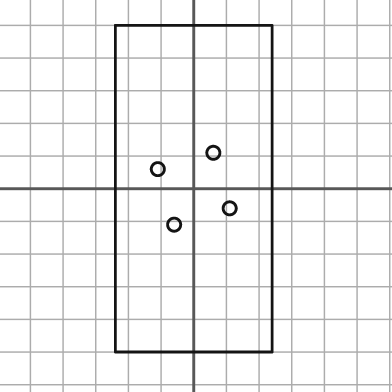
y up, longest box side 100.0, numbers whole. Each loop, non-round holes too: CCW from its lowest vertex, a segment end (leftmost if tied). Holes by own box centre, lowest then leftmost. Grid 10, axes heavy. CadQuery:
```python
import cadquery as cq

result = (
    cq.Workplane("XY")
    .moveTo(-24.0, -50.0)
    .lineTo(24.0, -50.0)
    .lineTo(24.0, 50.0)
    .lineTo(-24.0, 50.0)
    .close()
    .moveTo(-6.0, -11.0)
    .circle(2.0)
    .moveTo(11.0, -6.0)
    .circle(2.0)
    .moveTo(-11.0, 6.0)
    .circle(2.0)
    .moveTo(6.0, 11.0)
    .circle(2.0)
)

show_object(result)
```